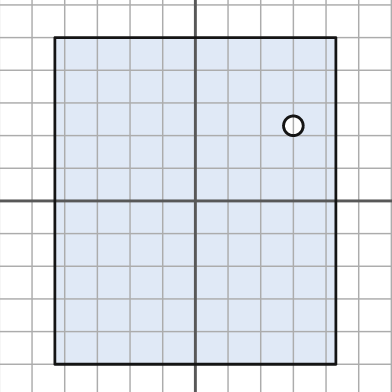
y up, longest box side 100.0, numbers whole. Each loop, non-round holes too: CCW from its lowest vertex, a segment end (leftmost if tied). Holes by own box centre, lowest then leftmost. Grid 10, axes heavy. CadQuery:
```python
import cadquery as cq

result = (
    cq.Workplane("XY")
    .moveTo(-43.0, -50.0)
    .lineTo(43.0, -50.0)
    .lineTo(43.0, 50.0)
    .lineTo(-43.0, 50.0)
    .close()
    .moveTo(30.0, 23.0)
    .circle(3.0)
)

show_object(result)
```